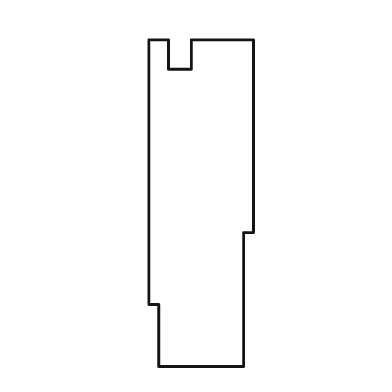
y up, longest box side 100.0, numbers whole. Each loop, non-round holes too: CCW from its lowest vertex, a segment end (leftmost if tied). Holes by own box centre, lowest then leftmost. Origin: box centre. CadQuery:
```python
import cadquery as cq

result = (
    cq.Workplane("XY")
    .moveTo(-13.0, -50.0)
    .lineTo(13.0, -50.0)
    .lineTo(13.0, -9.0)
    .lineTo(16.0, -9.0)
    .lineTo(16.0, 50.0)
    .lineTo(-3.0, 50.0)
    .lineTo(-3.0, 41.0)
    .lineTo(-10.0, 41.0)
    .lineTo(-10.0, 50.0)
    .lineTo(-16.0, 50.0)
    .lineTo(-16.0, -31.0)
    .lineTo(-13.0, -31.0)
    .close()
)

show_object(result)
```